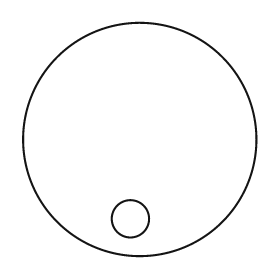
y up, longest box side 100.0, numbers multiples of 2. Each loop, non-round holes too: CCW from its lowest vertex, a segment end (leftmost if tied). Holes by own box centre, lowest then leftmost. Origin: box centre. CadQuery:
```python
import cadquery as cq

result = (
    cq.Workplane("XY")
    .moveTo(0.0, 0.0)
    .circle(50.0)
    .moveTo(-4.0, -34.0)
    .circle(8.0)
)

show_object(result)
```